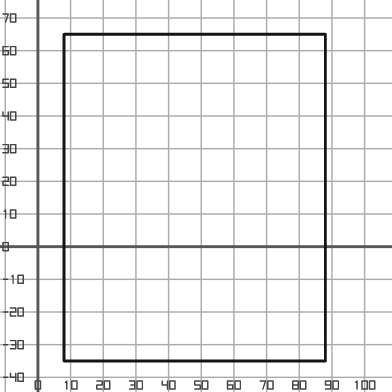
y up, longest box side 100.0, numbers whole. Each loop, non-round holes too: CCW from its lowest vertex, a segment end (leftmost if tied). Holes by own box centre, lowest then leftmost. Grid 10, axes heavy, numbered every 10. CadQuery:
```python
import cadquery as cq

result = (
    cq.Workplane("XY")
    .moveTo(8.0, -35.0)
    .lineTo(88.0, -35.0)
    .lineTo(88.0, 65.0)
    .lineTo(8.0, 65.0)
    .close()
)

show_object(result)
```